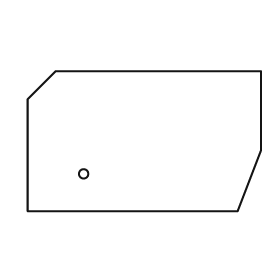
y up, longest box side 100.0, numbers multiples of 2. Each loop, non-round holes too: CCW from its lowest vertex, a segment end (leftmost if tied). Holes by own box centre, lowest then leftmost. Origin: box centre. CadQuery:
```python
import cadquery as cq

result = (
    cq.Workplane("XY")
    .moveTo(-50.0, -30.0)
    .lineTo(40.0, -30.0)
    .lineTo(50.0, -4.0)
    .lineTo(50.0, 30.0)
    .lineTo(-38.0, 30.0)
    .lineTo(-50.0, 18.0)
    .close()
    .moveTo(-26.0, -14.0)
    .circle(2.0)
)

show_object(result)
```